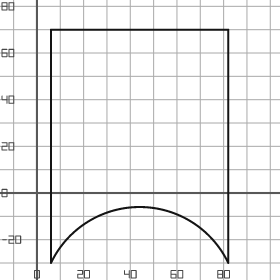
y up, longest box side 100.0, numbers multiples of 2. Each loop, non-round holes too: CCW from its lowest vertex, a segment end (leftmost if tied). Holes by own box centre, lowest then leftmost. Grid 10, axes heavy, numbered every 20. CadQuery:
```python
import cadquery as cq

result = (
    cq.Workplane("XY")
    .moveTo(6.0, -30.0)
    .threePointArc((44.0, -6.0), (82.0, -30.0))
    .lineTo(82.0, 70.0)
    .lineTo(6.0, 70.0)
    .close()
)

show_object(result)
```